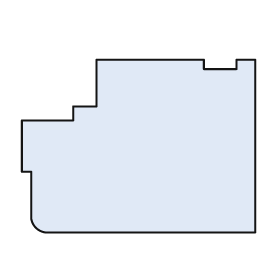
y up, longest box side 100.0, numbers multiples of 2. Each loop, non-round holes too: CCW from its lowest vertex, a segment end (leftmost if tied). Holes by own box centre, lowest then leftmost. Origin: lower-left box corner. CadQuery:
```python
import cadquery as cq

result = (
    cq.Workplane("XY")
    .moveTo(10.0, 0.0)
    .lineTo(100.0, 0.0)
    .lineTo(100.0, 74.0)
    .lineTo(92.0, 74.0)
    .lineTo(92.0, 70.0)
    .lineTo(78.0, 70.0)
    .lineTo(78.0, 74.0)
    .lineTo(32.0, 74.0)
    .lineTo(32.0, 54.0)
    .lineTo(22.0, 54.0)
    .lineTo(22.0, 48.0)
    .lineTo(0.0, 48.0)
    .lineTo(0.0, 26.0)
    .lineTo(4.0, 26.0)
    .lineTo(4.0, 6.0)
    .threePointArc((6.0, 2.0), (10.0, 0.0))
    .close()
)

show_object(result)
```